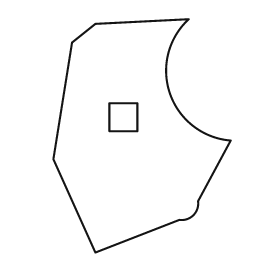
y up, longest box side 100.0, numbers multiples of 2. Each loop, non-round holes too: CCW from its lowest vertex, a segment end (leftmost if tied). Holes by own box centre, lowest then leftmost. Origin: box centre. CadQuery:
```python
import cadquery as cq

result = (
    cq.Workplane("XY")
    .moveTo(-20.0, -50.0)
    .lineTo(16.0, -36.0)
    .threePointArc((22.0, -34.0), (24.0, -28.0))
    .lineTo(38.0, -2.0)
    .threePointArc((12.0, 18.0), (20.0, 50.0))
    .lineTo(-20.0, 48.0)
    .lineTo(-30.0, 40.0)
    .lineTo(-38.0, -10.0)
    .close()
    .moveTo(-14.0, 2.0)
    .lineTo(-2.0, 2.0)
    .lineTo(-2.0, 14.0)
    .lineTo(-14.0, 14.0)
    .close()
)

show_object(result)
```